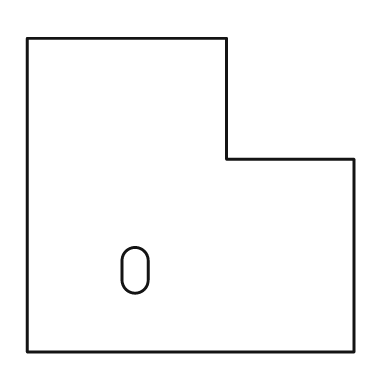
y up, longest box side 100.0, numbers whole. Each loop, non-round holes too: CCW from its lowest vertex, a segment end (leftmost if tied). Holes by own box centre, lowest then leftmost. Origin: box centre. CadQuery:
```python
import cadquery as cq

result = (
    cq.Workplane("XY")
    .moveTo(-50.0, -48.0)
    .lineTo(50.0, -48.0)
    .lineTo(50.0, 11.0)
    .lineTo(11.0, 11.0)
    .lineTo(11.0, 48.0)
    .lineTo(-50.0, 48.0)
    .close()
    .moveTo(-21.0, -26.0)
    .threePointArc((-17.0, -30.0), (-13.0, -26.0))
    .lineTo(-13.0, -20.0)
    .threePointArc((-17.0, -16.0), (-21.0, -20.0))
    .close()
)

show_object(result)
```